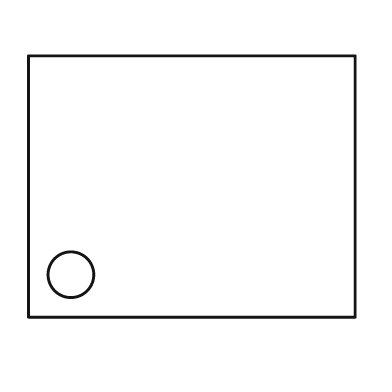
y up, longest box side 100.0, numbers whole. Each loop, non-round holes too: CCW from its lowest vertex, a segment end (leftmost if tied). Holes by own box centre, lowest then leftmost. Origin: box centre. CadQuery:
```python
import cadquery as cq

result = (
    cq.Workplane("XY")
    .moveTo(-50.0, -40.0)
    .lineTo(50.0, -40.0)
    .lineTo(50.0, 40.0)
    .lineTo(-50.0, 40.0)
    .close()
    .moveTo(-37.0, -27.0)
    .circle(7.0)
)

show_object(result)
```